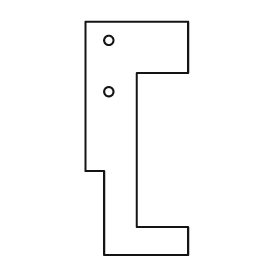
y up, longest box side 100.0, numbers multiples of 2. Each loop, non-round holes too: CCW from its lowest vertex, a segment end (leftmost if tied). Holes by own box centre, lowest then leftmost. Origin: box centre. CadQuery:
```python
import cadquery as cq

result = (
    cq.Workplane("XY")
    .moveTo(-14.0, -50.0)
    .lineTo(22.0, -50.0)
    .lineTo(22.0, -38.0)
    .lineTo(0.0, -38.0)
    .lineTo(0.0, 28.0)
    .lineTo(22.0, 28.0)
    .lineTo(22.0, 50.0)
    .lineTo(-22.0, 50.0)
    .lineTo(-22.0, -14.0)
    .lineTo(-14.0, -14.0)
    .close()
    .moveTo(-12.0, 20.0)
    .circle(2.0)
    .moveTo(-12.0, 42.0)
    .circle(2.0)
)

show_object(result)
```